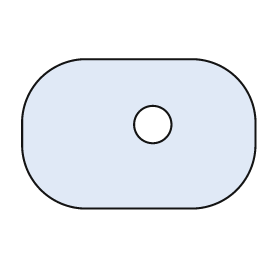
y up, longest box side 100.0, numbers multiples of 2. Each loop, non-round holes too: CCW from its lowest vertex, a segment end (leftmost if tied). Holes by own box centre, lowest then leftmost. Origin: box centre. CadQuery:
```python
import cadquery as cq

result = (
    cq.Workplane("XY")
    .moveTo(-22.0, -32.0)
    .lineTo(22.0, -32.0)
    .threePointArc((42.0, -24.0), (50.0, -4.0))
    .lineTo(50.0, 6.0)
    .threePointArc((42.0, 24.0), (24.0, 32.0))
    .lineTo(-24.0, 32.0)
    .threePointArc((-42.0, 24.0), (-50.0, 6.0))
    .lineTo(-50.0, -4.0)
    .threePointArc((-42.0, -24.0), (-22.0, -32.0))
    .close()
    .moveTo(6.0, 4.0)
    .circle(8.0)
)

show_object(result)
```